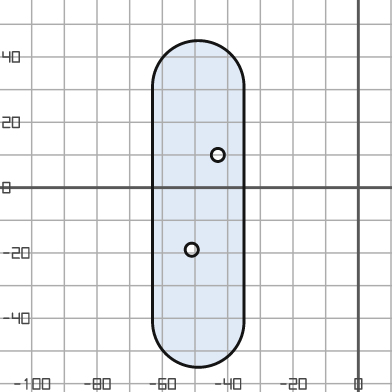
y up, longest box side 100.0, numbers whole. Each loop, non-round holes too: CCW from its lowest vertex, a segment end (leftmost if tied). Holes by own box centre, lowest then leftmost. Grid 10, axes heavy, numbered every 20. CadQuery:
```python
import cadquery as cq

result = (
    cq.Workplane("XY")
    .moveTo(-63.0, -41.0)
    .threePointArc((-49.0, -55.0), (-35.0, -41.0))
    .lineTo(-35.0, 31.0)
    .threePointArc((-49.0, 45.0), (-63.0, 31.0))
    .close()
    .moveTo(-51.0, -19.0)
    .circle(2.0)
    .moveTo(-43.0, 10.0)
    .circle(2.0)
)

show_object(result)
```